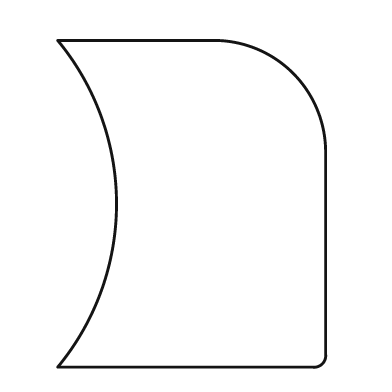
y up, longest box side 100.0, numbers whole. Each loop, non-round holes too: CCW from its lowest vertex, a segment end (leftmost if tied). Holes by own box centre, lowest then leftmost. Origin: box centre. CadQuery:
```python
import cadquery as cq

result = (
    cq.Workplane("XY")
    .moveTo(-41.0, -50.0)
    .lineTo(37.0, -50.0)
    .threePointArc((40.0, -49.0), (41.0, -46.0))
    .lineTo(41.0, 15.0)
    .threePointArc((31.0, 40.0), (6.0, 50.0))
    .lineTo(-41.0, 50.0)
    .threePointArc((-23.0, 0.0), (-41.0, -50.0))
    .close()
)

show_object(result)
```